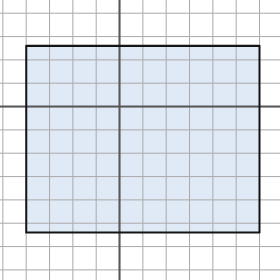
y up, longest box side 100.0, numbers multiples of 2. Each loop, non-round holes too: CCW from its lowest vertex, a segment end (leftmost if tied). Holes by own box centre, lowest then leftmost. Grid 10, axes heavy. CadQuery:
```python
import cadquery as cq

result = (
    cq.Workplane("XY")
    .moveTo(-40.0, -54.0)
    .lineTo(60.0, -54.0)
    .lineTo(60.0, 26.0)
    .lineTo(-40.0, 26.0)
    .close()
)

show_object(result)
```